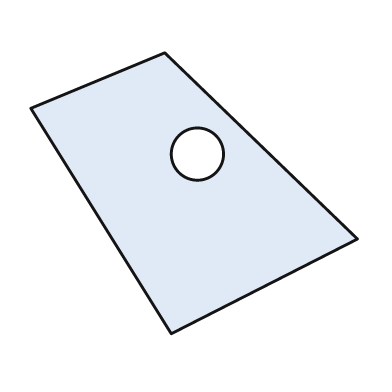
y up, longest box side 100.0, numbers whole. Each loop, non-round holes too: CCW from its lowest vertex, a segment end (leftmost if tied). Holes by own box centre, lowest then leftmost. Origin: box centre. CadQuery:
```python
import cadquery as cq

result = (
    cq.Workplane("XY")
    .moveTo(-7.0, -43.0)
    .lineTo(50.0, -14.0)
    .lineTo(-9.0, 43.0)
    .lineTo(-50.0, 26.0)
    .close()
    .moveTo(1.0, 12.0)
    .circle(8.0)
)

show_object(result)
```